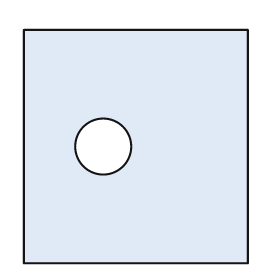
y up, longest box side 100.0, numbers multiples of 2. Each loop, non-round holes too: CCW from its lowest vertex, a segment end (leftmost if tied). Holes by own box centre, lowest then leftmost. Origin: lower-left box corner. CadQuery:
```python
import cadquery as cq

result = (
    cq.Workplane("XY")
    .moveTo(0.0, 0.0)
    .lineTo(96.0, 0.0)
    .lineTo(96.0, 100.0)
    .lineTo(0.0, 100.0)
    .close()
    .moveTo(34.0, 50.0)
    .circle(12.0)
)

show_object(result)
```